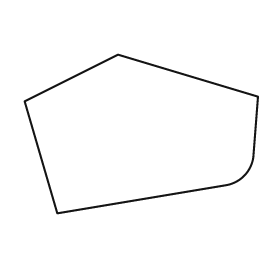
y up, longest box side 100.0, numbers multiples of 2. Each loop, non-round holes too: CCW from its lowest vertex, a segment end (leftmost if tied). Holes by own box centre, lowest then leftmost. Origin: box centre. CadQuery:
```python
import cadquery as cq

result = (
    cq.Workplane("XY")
    .moveTo(-36.0, -34.0)
    .lineTo(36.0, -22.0)
    .threePointArc((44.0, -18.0), (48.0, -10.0))
    .lineTo(50.0, 16.0)
    .lineTo(-10.0, 34.0)
    .lineTo(-50.0, 14.0)
    .close()
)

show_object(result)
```